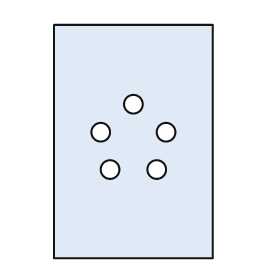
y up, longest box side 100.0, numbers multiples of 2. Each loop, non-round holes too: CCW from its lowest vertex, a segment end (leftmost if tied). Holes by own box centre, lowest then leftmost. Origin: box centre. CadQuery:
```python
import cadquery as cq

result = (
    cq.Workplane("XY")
    .moveTo(-34.0, -50.0)
    .lineTo(34.0, -50.0)
    .lineTo(34.0, 50.0)
    .lineTo(-34.0, 50.0)
    .close()
    .moveTo(-10.0, -12.0)
    .circle(4.0)
    .moveTo(10.0, -12.0)
    .circle(4.0)
    .moveTo(-14.0, 4.0)
    .circle(4.0)
    .moveTo(14.0, 4.0)
    .circle(4.0)
    .moveTo(0.0, 16.0)
    .circle(4.0)
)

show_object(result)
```